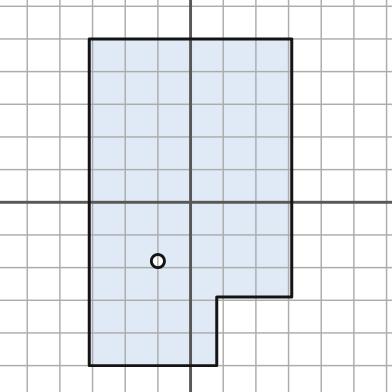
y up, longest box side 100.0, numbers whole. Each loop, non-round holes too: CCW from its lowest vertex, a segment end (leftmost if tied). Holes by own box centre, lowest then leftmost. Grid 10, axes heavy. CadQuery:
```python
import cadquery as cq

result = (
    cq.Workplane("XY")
    .moveTo(-31.0, -50.0)
    .lineTo(8.0, -50.0)
    .lineTo(8.0, -29.0)
    .lineTo(31.0, -29.0)
    .lineTo(31.0, 50.0)
    .lineTo(-31.0, 50.0)
    .close()
    .moveTo(-10.0, -18.0)
    .circle(2.0)
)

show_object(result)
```